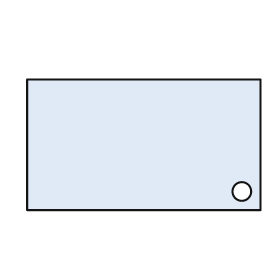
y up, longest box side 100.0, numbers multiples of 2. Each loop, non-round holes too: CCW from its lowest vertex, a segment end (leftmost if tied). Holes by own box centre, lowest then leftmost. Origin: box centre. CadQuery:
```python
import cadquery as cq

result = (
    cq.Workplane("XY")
    .moveTo(-50.0, -28.0)
    .lineTo(50.0, -28.0)
    .lineTo(50.0, 28.0)
    .lineTo(-50.0, 28.0)
    .close()
    .moveTo(42.0, -20.0)
    .circle(4.0)
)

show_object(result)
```